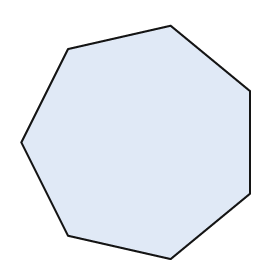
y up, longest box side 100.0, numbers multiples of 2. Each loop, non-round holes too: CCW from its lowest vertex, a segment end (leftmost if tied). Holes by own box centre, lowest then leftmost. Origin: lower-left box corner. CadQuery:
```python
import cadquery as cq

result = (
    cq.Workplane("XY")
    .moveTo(64.0, 0.0)
    .lineTo(98.0, 28.0)
    .lineTo(98.0, 72.0)
    .lineTo(64.0, 100.0)
    .lineTo(20.0, 90.0)
    .lineTo(0.0, 50.0)
    .lineTo(20.0, 10.0)
    .close()
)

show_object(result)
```